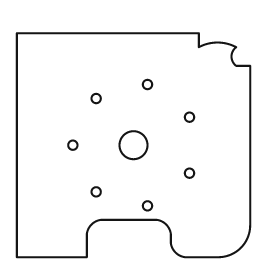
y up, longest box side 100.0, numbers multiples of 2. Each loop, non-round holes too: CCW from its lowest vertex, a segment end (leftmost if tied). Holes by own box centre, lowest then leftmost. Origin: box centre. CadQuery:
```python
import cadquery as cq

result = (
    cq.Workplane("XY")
    .moveTo(-50.0, -48.0)
    .lineTo(-20.0, -48.0)
    .lineTo(-20.0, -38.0)
    .threePointArc((-18.0, -34.0), (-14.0, -32.0))
    .lineTo(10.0, -32.0)
    .threePointArc((14.0, -34.0), (16.0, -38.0))
    .lineTo(16.0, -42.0)
    .threePointArc((18.0, -46.0), (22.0, -48.0))
    .lineTo(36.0, -48.0)
    .threePointArc((46.0, -44.0), (50.0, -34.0))
    .lineTo(50.0, 34.0)
    .lineTo(44.0, 34.0)
    .threePointArc((42.0, 38.0), (44.0, 42.0))
    .threePointArc((36.0, 44.0), (28.0, 42.0))
    .lineTo(28.0, 48.0)
    .lineTo(-50.0, 48.0)
    .close()
    .moveTo(6.0, -26.0)
    .circle(2.0)
    .moveTo(-16.0, -20.0)
    .circle(2.0)
    .moveTo(24.0, -12.0)
    .circle(2.0)
    .moveTo(-26.0, 0.0)
    .circle(2.0)
    .moveTo(0.0, 0.0)
    .circle(6.0)
    .moveTo(24.0, 12.0)
    .circle(2.0)
    .moveTo(-16.0, 20.0)
    .circle(2.0)
    .moveTo(6.0, 26.0)
    .circle(2.0)
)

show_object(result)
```